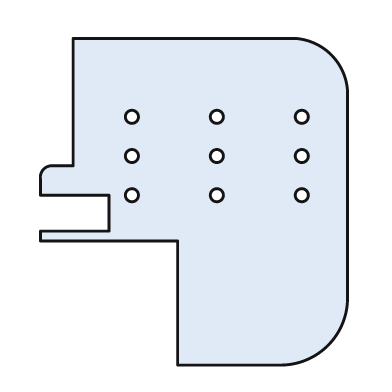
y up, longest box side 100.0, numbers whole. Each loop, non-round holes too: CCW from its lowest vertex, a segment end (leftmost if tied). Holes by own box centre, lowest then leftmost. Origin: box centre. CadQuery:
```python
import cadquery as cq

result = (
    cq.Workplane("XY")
    .moveTo(-5.0, -50.0)
    .lineTo(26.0, -50.0)
    .threePointArc((41.0, -44.0), (47.0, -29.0))
    .lineTo(47.0, 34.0)
    .threePointArc((42.0, 45.0), (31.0, 50.0))
    .lineTo(-37.0, 50.0)
    .lineTo(-37.0, 11.0)
    .lineTo(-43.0, 11.0)
    .threePointArc((-46.0, 10.0), (-47.0, 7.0))
    .lineTo(-47.0, 2.0)
    .lineTo(-26.0, 2.0)
    .lineTo(-26.0, -9.0)
    .lineTo(-47.0, -9.0)
    .lineTo(-47.0, -12.0)
    .lineTo(-5.0, -12.0)
    .close()
    .moveTo(-19.0, 2.0)
    .circle(2.0)
    .moveTo(7.0, 2.0)
    .circle(2.0)
    .moveTo(33.0, 2.0)
    .circle(2.0)
    .moveTo(-19.0, 14.0)
    .circle(2.0)
    .moveTo(7.0, 14.0)
    .circle(2.0)
    .moveTo(33.0, 14.0)
    .circle(2.0)
    .moveTo(-19.0, 26.0)
    .circle(2.0)
    .moveTo(7.0, 26.0)
    .circle(2.0)
    .moveTo(33.0, 26.0)
    .circle(2.0)
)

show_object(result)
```